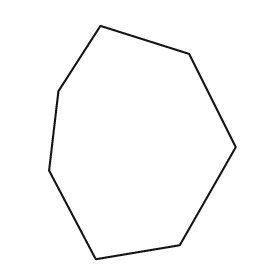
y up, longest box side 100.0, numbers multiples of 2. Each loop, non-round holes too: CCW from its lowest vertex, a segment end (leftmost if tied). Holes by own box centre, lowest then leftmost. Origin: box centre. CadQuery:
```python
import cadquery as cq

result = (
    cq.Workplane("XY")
    .moveTo(-20.0, -50.0)
    .lineTo(16.0, -44.0)
    .lineTo(40.0, -2.0)
    .lineTo(20.0, 38.0)
    .lineTo(-18.0, 50.0)
    .lineTo(-36.0, 22.0)
    .lineTo(-40.0, -12.0)
    .close()
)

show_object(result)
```